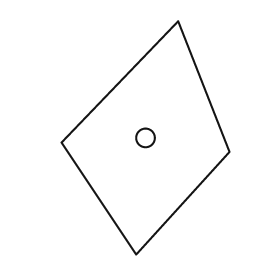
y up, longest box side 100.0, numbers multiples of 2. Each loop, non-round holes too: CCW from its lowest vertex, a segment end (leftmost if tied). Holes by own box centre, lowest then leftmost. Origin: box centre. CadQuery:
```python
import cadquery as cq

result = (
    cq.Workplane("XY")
    .moveTo(-4.0, -50.0)
    .lineTo(36.0, -6.0)
    .lineTo(14.0, 50.0)
    .lineTo(-36.0, -2.0)
    .close()
    .moveTo(0.0, 0.0)
    .circle(4.0)
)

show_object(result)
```